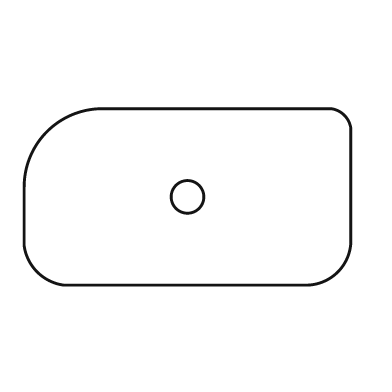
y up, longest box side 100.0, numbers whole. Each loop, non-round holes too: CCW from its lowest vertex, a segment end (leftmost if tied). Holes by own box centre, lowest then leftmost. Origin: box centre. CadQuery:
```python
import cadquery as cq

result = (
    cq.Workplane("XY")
    .moveTo(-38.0, -27.0)
    .lineTo(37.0, -27.0)
    .threePointArc((46.0, -23.0), (50.0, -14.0))
    .lineTo(50.0, 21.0)
    .threePointArc((48.0, 25.0), (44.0, 27.0))
    .lineTo(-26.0, 27.0)
    .threePointArc((-43.0, 20.0), (-50.0, 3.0))
    .lineTo(-50.0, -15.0)
    .threePointArc((-46.0, -23.0), (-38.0, -27.0))
    .close()
    .moveTo(0.0, 0.0)
    .circle(5.0)
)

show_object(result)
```